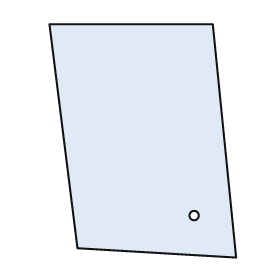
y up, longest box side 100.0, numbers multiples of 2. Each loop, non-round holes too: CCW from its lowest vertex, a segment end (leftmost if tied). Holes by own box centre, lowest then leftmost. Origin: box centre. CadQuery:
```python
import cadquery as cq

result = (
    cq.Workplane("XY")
    .moveTo(40.0, -50.0)
    .lineTo(30.0, 50.0)
    .lineTo(-40.0, 50.0)
    .lineTo(-28.0, -46.0)
    .close()
    .moveTo(22.0, -32.0)
    .circle(2.0)
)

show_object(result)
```